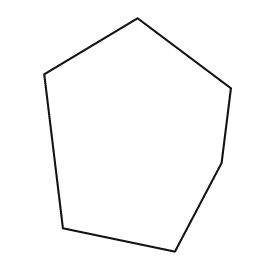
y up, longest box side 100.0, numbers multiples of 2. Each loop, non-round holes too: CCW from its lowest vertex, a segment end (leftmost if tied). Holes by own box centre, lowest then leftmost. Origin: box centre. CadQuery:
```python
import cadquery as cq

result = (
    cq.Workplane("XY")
    .moveTo(16.0, -50.0)
    .lineTo(36.0, -12.0)
    .lineTo(40.0, 20.0)
    .lineTo(0.0, 50.0)
    .lineTo(-40.0, 26.0)
    .lineTo(-32.0, -40.0)
    .close()
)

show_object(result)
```